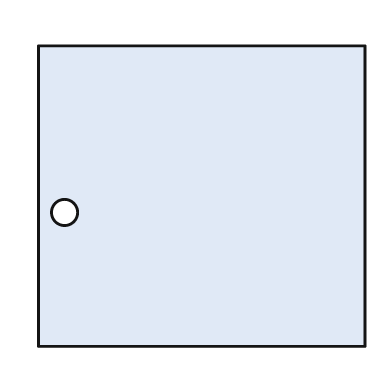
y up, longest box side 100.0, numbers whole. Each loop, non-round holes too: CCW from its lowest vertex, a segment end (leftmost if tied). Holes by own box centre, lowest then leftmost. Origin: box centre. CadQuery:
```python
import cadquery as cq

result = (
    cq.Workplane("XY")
    .moveTo(-50.0, -46.0)
    .lineTo(50.0, -46.0)
    .lineTo(50.0, 46.0)
    .lineTo(-50.0, 46.0)
    .close()
    .moveTo(-42.0, -5.0)
    .circle(4.0)
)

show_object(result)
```